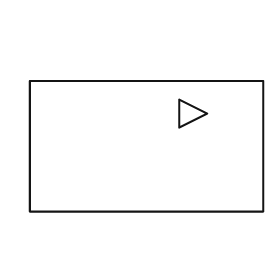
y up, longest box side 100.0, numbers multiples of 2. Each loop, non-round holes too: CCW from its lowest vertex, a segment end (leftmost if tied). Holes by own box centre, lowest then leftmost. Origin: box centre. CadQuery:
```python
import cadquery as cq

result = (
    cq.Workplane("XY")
    .moveTo(-50.0, -28.0)
    .lineTo(50.0, -28.0)
    .lineTo(50.0, 28.0)
    .lineTo(-50.0, 28.0)
    .close()
    .moveTo(14.0, 8.0)
    .lineTo(26.0, 14.0)
    .lineTo(14.0, 20.0)
    .close()
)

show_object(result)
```